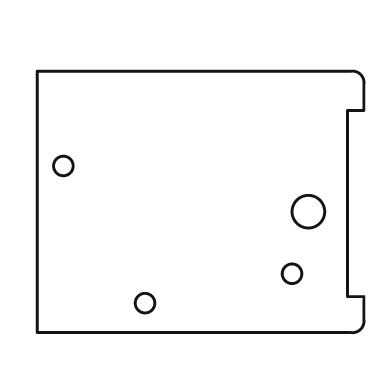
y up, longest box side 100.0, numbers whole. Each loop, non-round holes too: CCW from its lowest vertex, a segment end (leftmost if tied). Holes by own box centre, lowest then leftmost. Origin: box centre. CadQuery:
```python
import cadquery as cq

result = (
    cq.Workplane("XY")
    .moveTo(-50.0, -40.0)
    .lineTo(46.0, -40.0)
    .threePointArc((49.0, -39.0), (50.0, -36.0))
    .lineTo(50.0, -29.0)
    .lineTo(45.0, -29.0)
    .lineTo(45.0, 28.0)
    .lineTo(50.0, 28.0)
    .lineTo(50.0, 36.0)
    .threePointArc((49.0, 39.0), (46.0, 40.0))
    .lineTo(-50.0, 40.0)
    .close()
    .moveTo(-17.0, -31.0)
    .circle(3.0)
    .moveTo(28.0, -22.0)
    .circle(3.0)
    .moveTo(33.0, -3.0)
    .circle(5.0)
    .moveTo(-42.0, 11.0)
    .circle(3.0)
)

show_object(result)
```